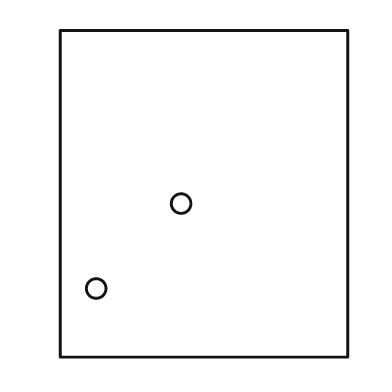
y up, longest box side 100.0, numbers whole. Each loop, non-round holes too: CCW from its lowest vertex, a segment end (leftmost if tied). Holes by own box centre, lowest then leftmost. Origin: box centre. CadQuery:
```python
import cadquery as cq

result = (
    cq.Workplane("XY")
    .moveTo(-44.0, -50.0)
    .lineTo(44.0, -50.0)
    .lineTo(44.0, 50.0)
    .lineTo(-44.0, 50.0)
    .close()
    .moveTo(-33.0, -29.0)
    .circle(3.0)
    .moveTo(-7.0, -3.0)
    .circle(3.0)
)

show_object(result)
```